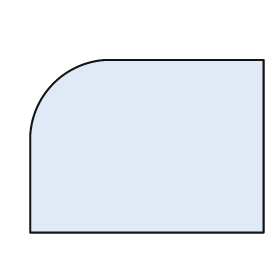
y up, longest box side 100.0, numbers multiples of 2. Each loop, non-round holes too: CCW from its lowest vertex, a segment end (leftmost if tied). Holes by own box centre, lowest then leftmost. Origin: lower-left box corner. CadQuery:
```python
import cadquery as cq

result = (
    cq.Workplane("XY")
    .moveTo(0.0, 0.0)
    .lineTo(100.0, 0.0)
    .lineTo(100.0, 74.0)
    .lineTo(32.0, 74.0)
    .threePointArc((10.0, 64.0), (0.0, 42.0))
    .close()
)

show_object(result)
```